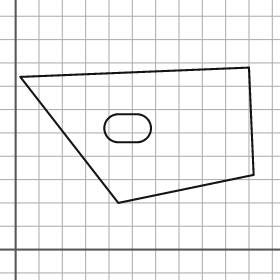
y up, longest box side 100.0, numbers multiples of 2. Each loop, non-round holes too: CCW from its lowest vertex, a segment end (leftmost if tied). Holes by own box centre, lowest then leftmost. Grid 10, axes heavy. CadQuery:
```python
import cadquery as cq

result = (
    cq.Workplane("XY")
    .moveTo(44.0, 20.0)
    .lineTo(102.0, 32.0)
    .lineTo(100.0, 78.0)
    .lineTo(2.0, 74.0)
    .close()
    .moveTo(44.0, 46.0)
    .lineTo(52.0, 46.0)
    .threePointArc((58.0, 52.0), (52.0, 58.0))
    .lineTo(44.0, 58.0)
    .threePointArc((38.0, 52.0), (44.0, 46.0))
    .close()
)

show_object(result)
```